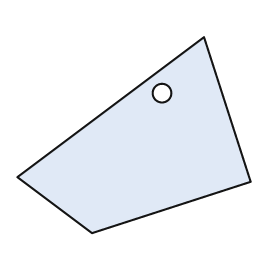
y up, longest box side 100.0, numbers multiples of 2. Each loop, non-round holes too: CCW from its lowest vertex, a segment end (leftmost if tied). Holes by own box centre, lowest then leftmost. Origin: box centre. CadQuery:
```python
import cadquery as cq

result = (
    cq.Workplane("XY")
    .moveTo(-18.0, -42.0)
    .lineTo(50.0, -20.0)
    .lineTo(30.0, 42.0)
    .lineTo(-50.0, -18.0)
    .close()
    .moveTo(12.0, 18.0)
    .circle(4.0)
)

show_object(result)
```